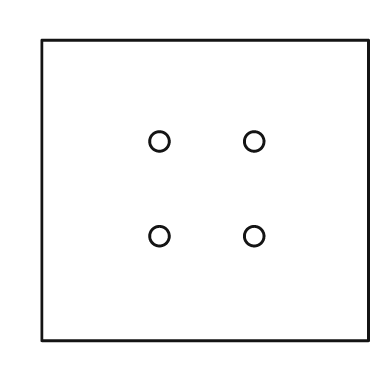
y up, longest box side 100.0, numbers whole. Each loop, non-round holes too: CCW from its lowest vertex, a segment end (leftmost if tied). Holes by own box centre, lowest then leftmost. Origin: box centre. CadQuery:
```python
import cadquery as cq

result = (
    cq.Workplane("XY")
    .moveTo(-50.0, -46.0)
    .lineTo(50.0, -46.0)
    .lineTo(50.0, 46.0)
    .lineTo(-50.0, 46.0)
    .close()
    .moveTo(-14.0, -14.0)
    .circle(3.0)
    .moveTo(15.0, -14.0)
    .circle(3.0)
    .moveTo(-14.0, 15.0)
    .circle(3.0)
    .moveTo(15.0, 15.0)
    .circle(3.0)
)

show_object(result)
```